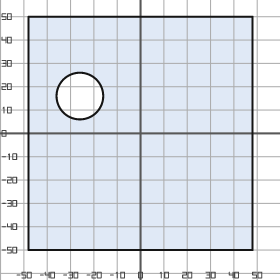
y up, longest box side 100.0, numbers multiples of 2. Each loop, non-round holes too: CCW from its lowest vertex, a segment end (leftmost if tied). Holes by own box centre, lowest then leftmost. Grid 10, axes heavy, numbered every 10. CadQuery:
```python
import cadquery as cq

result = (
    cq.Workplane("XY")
    .moveTo(-48.0, -50.0)
    .lineTo(48.0, -50.0)
    .lineTo(48.0, 50.0)
    .lineTo(-48.0, 50.0)
    .close()
    .moveTo(-26.0, 16.0)
    .circle(10.0)
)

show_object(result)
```